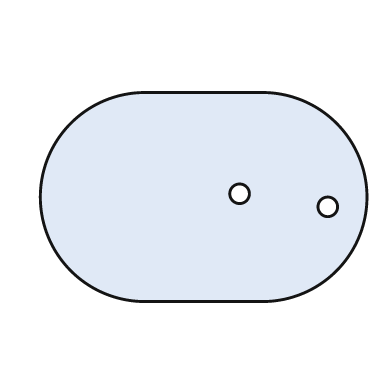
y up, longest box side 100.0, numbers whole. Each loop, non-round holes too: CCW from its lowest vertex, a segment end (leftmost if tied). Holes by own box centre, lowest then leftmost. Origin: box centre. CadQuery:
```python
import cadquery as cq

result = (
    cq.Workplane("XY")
    .moveTo(-18.0, -32.0)
    .lineTo(18.0, -32.0)
    .threePointArc((50.0, 0.0), (18.0, 32.0))
    .lineTo(-18.0, 32.0)
    .threePointArc((-50.0, 0.0), (-18.0, -32.0))
    .close()
    .moveTo(38.0, -3.0)
    .circle(3.0)
    .moveTo(11.0, 1.0)
    .circle(3.0)
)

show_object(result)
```